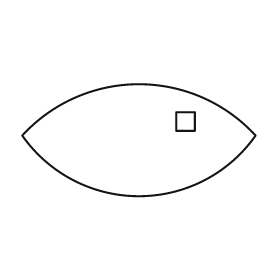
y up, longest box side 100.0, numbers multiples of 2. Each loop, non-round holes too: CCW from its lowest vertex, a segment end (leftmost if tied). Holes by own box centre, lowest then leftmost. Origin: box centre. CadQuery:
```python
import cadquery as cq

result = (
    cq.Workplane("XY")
    .moveTo(-50.0, 2.0)
    .threePointArc((0.0, -24.0), (50.0, 2.0))
    .threePointArc((0.0, 24.0), (-50.0, 2.0))
    .close()
    .moveTo(16.0, 4.0)
    .lineTo(24.0, 4.0)
    .lineTo(24.0, 12.0)
    .lineTo(16.0, 12.0)
    .close()
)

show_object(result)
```